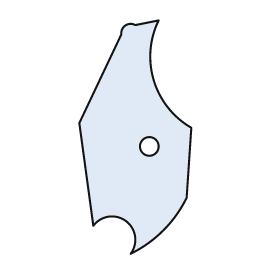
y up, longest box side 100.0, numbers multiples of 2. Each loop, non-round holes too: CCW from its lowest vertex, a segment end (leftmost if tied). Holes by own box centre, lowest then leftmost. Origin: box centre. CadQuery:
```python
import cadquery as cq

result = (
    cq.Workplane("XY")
    .moveTo(-2.0, -50.0)
    .threePointArc((12.0, -40.0), (22.0, -26.0))
    .lineTo(24.0, 4.0)
    .threePointArc((8.0, 24.0), (10.0, 50.0))
    .lineTo(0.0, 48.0)
    .threePointArc((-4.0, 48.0), (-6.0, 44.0))
    .lineTo(-24.0, 6.0)
    .lineTo(-18.0, -38.0)
    .threePointArc((-4.0, -36.0), (-2.0, -50.0))
    .close()
    .moveTo(6.0, -4.0)
    .circle(4.0)
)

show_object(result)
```